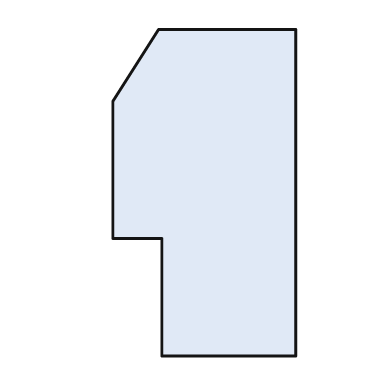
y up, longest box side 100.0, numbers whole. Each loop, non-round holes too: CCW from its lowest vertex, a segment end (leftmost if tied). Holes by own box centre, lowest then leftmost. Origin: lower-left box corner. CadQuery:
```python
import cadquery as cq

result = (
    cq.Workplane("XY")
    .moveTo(15.0, 0.0)
    .lineTo(56.0, 0.0)
    .lineTo(56.0, 100.0)
    .lineTo(14.0, 100.0)
    .lineTo(0.0, 78.0)
    .lineTo(0.0, 36.0)
    .lineTo(15.0, 36.0)
    .close()
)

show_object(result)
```